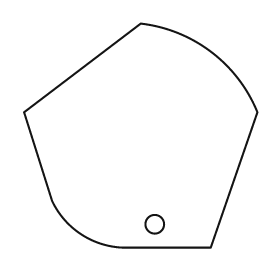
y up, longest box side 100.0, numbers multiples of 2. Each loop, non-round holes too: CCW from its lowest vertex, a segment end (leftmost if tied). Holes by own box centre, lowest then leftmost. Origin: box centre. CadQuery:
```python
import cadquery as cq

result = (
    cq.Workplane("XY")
    .moveTo(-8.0, -48.0)
    .lineTo(30.0, -48.0)
    .lineTo(50.0, 10.0)
    .threePointArc((30.0, 36.0), (0.0, 48.0))
    .lineTo(-50.0, 10.0)
    .lineTo(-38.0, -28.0)
    .threePointArc((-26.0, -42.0), (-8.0, -48.0))
    .close()
    .moveTo(6.0, -38.0)
    .circle(4.0)
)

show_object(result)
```